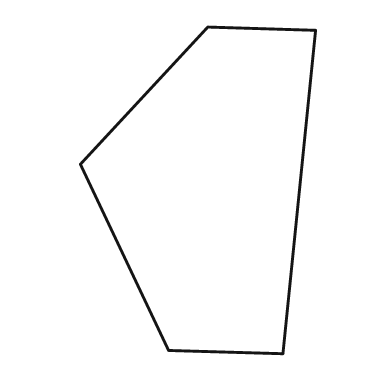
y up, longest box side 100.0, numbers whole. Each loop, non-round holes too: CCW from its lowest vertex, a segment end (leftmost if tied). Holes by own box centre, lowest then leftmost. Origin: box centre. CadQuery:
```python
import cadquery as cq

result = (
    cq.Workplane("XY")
    .moveTo(26.0, -50.0)
    .lineTo(36.0, 49.0)
    .lineTo(3.0, 50.0)
    .lineTo(-36.0, 8.0)
    .lineTo(-9.0, -49.0)
    .close()
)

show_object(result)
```